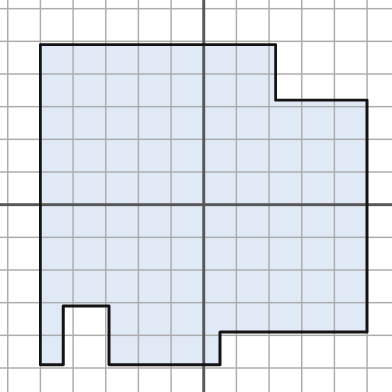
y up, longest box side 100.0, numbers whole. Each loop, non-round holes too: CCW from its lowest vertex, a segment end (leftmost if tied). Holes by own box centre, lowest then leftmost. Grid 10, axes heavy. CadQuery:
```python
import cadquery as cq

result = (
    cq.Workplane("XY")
    .moveTo(-50.0, -49.0)
    .lineTo(-43.0, -49.0)
    .lineTo(-43.0, -31.0)
    .lineTo(-29.0, -31.0)
    .lineTo(-29.0, -49.0)
    .lineTo(5.0, -49.0)
    .lineTo(5.0, -39.0)
    .lineTo(50.0, -39.0)
    .lineTo(50.0, 32.0)
    .lineTo(22.0, 32.0)
    .lineTo(22.0, 49.0)
    .lineTo(-50.0, 49.0)
    .close()
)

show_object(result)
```